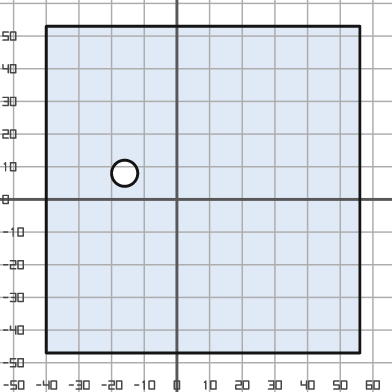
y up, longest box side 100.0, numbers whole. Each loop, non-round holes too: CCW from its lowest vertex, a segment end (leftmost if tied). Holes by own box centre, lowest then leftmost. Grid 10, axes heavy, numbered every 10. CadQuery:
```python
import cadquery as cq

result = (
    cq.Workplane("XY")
    .moveTo(-40.0, -47.0)
    .lineTo(56.0, -47.0)
    .lineTo(56.0, 53.0)
    .lineTo(-40.0, 53.0)
    .close()
    .moveTo(-16.0, 8.0)
    .circle(4.0)
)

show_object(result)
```